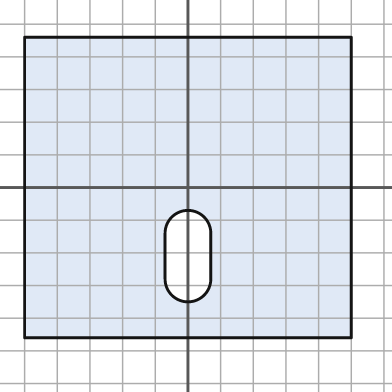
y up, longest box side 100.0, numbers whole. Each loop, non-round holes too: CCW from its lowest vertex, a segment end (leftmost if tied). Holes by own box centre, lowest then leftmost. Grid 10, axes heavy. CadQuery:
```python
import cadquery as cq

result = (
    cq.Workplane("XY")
    .moveTo(-50.0, -46.0)
    .lineTo(50.0, -46.0)
    .lineTo(50.0, 46.0)
    .lineTo(-50.0, 46.0)
    .close()
    .moveTo(-7.0, -28.0)
    .threePointArc((0.0, -35.0), (7.0, -28.0))
    .lineTo(7.0, -14.0)
    .threePointArc((0.0, -7.0), (-7.0, -14.0))
    .close()
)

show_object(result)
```